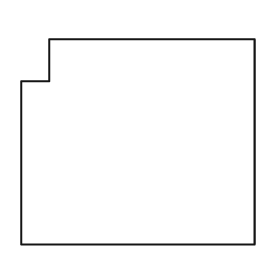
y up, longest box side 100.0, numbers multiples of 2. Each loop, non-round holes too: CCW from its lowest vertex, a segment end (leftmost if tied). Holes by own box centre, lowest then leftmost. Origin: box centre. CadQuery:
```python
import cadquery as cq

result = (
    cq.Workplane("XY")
    .moveTo(-50.0, -44.0)
    .lineTo(50.0, -44.0)
    .lineTo(50.0, 44.0)
    .lineTo(-38.0, 44.0)
    .lineTo(-38.0, 26.0)
    .lineTo(-50.0, 26.0)
    .close()
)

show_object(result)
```